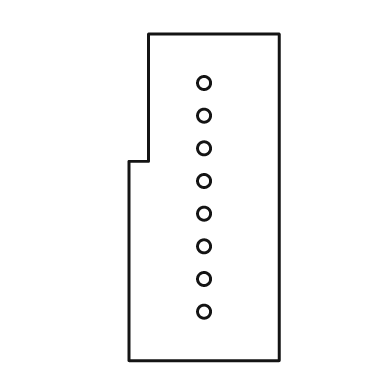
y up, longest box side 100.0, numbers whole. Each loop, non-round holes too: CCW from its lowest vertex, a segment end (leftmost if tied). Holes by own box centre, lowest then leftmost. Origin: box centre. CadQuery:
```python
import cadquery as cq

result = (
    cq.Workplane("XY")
    .moveTo(-23.0, -50.0)
    .lineTo(23.0, -50.0)
    .lineTo(23.0, 50.0)
    .lineTo(-17.0, 50.0)
    .lineTo(-17.0, 11.0)
    .lineTo(-23.0, 11.0)
    .close()
    .moveTo(0.0, -35.0)
    .circle(2.0)
    .moveTo(0.0, -25.0)
    .circle(2.0)
    .moveTo(0.0, -15.0)
    .circle(2.0)
    .moveTo(0.0, -5.0)
    .circle(2.0)
    .moveTo(0.0, 5.0)
    .circle(2.0)
    .moveTo(0.0, 15.0)
    .circle(2.0)
    .moveTo(0.0, 25.0)
    .circle(2.0)
    .moveTo(0.0, 35.0)
    .circle(2.0)
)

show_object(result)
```